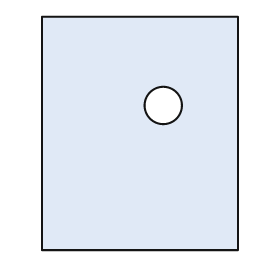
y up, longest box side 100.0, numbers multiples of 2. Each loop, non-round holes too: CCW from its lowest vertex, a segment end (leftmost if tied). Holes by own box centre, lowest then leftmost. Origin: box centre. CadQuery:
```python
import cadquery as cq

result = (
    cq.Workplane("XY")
    .moveTo(-42.0, -50.0)
    .lineTo(42.0, -50.0)
    .lineTo(42.0, 50.0)
    .lineTo(-42.0, 50.0)
    .close()
    .moveTo(10.0, 12.0)
    .circle(8.0)
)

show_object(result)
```